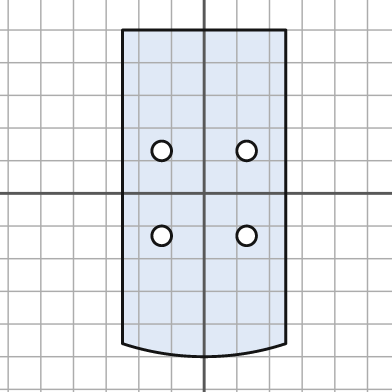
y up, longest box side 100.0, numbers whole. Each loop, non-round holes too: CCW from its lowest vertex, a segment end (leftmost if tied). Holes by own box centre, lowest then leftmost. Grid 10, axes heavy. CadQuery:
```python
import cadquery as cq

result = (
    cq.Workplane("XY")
    .moveTo(-25.0, -46.0)
    .threePointArc((0.0, -50.0), (25.0, -46.0))
    .lineTo(25.0, 50.0)
    .lineTo(-25.0, 50.0)
    .close()
    .moveTo(-13.0, -13.0)
    .circle(3.0)
    .moveTo(13.0, -13.0)
    .circle(3.0)
    .moveTo(-13.0, 13.0)
    .circle(3.0)
    .moveTo(13.0, 13.0)
    .circle(3.0)
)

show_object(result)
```